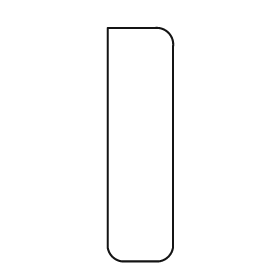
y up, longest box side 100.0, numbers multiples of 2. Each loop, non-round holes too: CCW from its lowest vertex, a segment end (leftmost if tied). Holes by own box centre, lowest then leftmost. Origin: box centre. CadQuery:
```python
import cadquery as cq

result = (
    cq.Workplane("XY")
    .moveTo(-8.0, -50.0)
    .lineTo(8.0, -50.0)
    .threePointArc((12.0, -48.0), (14.0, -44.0))
    .lineTo(14.0, 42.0)
    .threePointArc((12.0, 48.0), (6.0, 50.0))
    .lineTo(-14.0, 50.0)
    .lineTo(-14.0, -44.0)
    .threePointArc((-12.0, -48.0), (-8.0, -50.0))
    .close()
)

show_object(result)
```